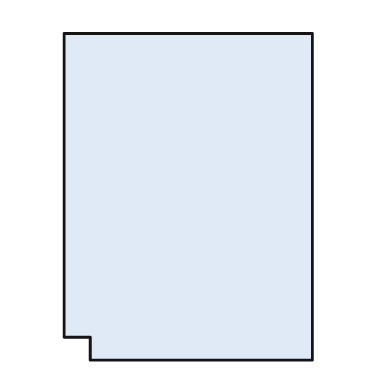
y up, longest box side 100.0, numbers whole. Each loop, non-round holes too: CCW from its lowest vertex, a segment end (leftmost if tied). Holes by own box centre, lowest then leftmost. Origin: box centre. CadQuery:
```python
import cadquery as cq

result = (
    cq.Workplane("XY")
    .moveTo(-30.0, -50.0)
    .lineTo(38.0, -50.0)
    .lineTo(38.0, 50.0)
    .lineTo(-38.0, 50.0)
    .lineTo(-38.0, -43.0)
    .lineTo(-30.0, -43.0)
    .close()
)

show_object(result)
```